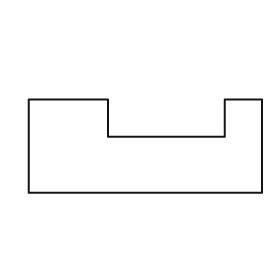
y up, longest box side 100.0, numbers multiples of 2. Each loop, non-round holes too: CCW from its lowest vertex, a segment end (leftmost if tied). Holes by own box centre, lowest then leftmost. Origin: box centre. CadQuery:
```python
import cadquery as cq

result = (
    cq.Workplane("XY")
    .moveTo(-50.0, -20.0)
    .lineTo(50.0, -20.0)
    .lineTo(50.0, 20.0)
    .lineTo(34.0, 20.0)
    .lineTo(34.0, 4.0)
    .lineTo(-16.0, 4.0)
    .lineTo(-16.0, 20.0)
    .lineTo(-50.0, 20.0)
    .close()
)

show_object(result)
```